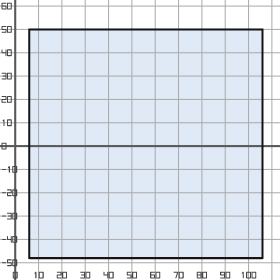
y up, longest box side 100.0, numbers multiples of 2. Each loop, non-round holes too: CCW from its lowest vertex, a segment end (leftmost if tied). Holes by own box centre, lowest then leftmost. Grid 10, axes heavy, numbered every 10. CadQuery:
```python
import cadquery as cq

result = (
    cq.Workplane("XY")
    .moveTo(6.0, -48.0)
    .lineTo(106.0, -48.0)
    .lineTo(106.0, 50.0)
    .lineTo(6.0, 50.0)
    .close()
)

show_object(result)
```